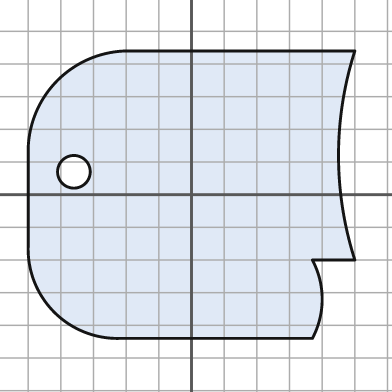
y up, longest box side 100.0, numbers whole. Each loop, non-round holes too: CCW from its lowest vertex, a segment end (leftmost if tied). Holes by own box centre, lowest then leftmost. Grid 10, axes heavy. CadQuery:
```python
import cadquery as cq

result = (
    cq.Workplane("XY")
    .moveTo(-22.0, -44.0)
    .lineTo(37.0, -44.0)
    .threePointArc((40.0, -32.0), (37.0, -20.0))
    .lineTo(50.0, -20.0)
    .threePointArc((45.0, 12.0), (50.0, 44.0))
    .lineTo(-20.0, 44.0)
    .threePointArc((-41.0, 35.0), (-50.0, 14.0))
    .lineTo(-50.0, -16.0)
    .threePointArc((-42.0, -36.0), (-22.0, -44.0))
    .close()
    .moveTo(-36.0, 7.0)
    .circle(5.0)
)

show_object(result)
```